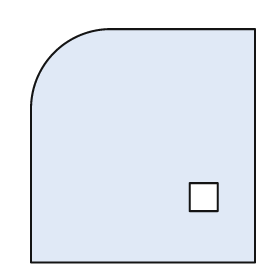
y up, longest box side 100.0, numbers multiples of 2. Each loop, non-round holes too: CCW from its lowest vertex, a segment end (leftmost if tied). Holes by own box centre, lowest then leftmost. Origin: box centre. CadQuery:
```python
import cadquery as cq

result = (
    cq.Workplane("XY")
    .moveTo(-48.0, -50.0)
    .lineTo(48.0, -50.0)
    .lineTo(48.0, 50.0)
    .lineTo(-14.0, 50.0)
    .threePointArc((-38.0, 40.0), (-48.0, 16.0))
    .close()
    .moveTo(20.0, -28.0)
    .lineTo(32.0, -28.0)
    .lineTo(32.0, -16.0)
    .lineTo(20.0, -16.0)
    .close()
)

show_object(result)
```